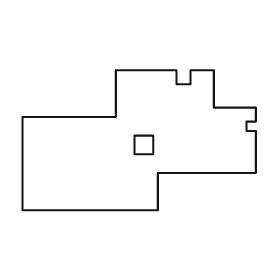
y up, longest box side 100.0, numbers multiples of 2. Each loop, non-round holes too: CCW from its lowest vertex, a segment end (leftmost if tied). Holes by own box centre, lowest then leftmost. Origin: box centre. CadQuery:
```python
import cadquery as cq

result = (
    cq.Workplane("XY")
    .moveTo(-50.0, -30.0)
    .lineTo(8.0, -30.0)
    .lineTo(8.0, -14.0)
    .lineTo(50.0, -14.0)
    .lineTo(50.0, 4.0)
    .lineTo(46.0, 4.0)
    .lineTo(46.0, 8.0)
    .lineTo(50.0, 8.0)
    .lineTo(50.0, 14.0)
    .lineTo(32.0, 14.0)
    .lineTo(32.0, 30.0)
    .lineTo(22.0, 30.0)
    .lineTo(22.0, 24.0)
    .lineTo(16.0, 24.0)
    .lineTo(16.0, 30.0)
    .lineTo(-10.0, 30.0)
    .lineTo(-10.0, 10.0)
    .lineTo(-50.0, 10.0)
    .close()
    .moveTo(-2.0, -6.0)
    .lineTo(6.0, -6.0)
    .lineTo(6.0, 2.0)
    .lineTo(-2.0, 2.0)
    .close()
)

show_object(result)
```